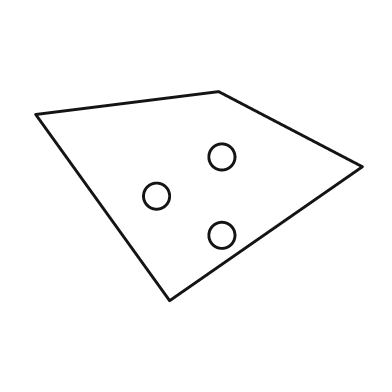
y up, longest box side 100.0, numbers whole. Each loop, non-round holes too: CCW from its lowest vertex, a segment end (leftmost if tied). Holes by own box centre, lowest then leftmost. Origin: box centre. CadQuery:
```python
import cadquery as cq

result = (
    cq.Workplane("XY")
    .moveTo(-9.0, -32.0)
    .lineTo(50.0, 9.0)
    .lineTo(6.0, 32.0)
    .lineTo(-50.0, 25.0)
    .close()
    .moveTo(7.0, -12.0)
    .circle(4.0)
    .moveTo(-13.0, 0.0)
    .circle(4.0)
    .moveTo(7.0, 12.0)
    .circle(4.0)
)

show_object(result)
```